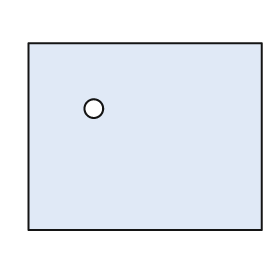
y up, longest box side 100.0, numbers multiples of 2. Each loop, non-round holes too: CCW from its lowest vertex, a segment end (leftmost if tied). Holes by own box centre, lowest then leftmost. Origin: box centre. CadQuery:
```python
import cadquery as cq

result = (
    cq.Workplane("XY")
    .moveTo(-50.0, -40.0)
    .lineTo(50.0, -40.0)
    .lineTo(50.0, 40.0)
    .lineTo(-50.0, 40.0)
    .close()
    .moveTo(-22.0, 12.0)
    .circle(4.0)
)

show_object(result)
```